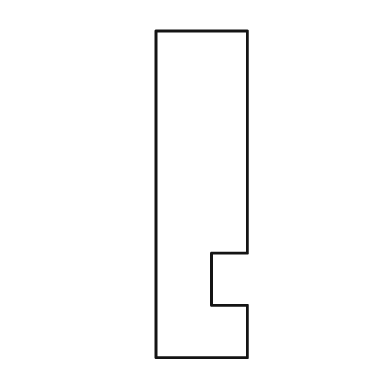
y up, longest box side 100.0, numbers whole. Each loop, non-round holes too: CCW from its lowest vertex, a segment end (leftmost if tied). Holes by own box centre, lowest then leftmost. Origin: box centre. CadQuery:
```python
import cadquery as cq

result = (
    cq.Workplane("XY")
    .moveTo(-14.0, -50.0)
    .lineTo(14.0, -50.0)
    .lineTo(14.0, -34.0)
    .lineTo(3.0, -34.0)
    .lineTo(3.0, -18.0)
    .lineTo(14.0, -18.0)
    .lineTo(14.0, 50.0)
    .lineTo(-14.0, 50.0)
    .close()
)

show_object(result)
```